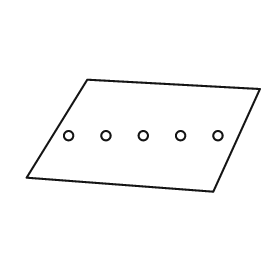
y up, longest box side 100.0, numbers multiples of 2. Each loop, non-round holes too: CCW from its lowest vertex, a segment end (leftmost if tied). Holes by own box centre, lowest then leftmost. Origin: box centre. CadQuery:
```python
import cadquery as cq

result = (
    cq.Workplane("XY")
    .moveTo(30.0, -24.0)
    .lineTo(50.0, 20.0)
    .lineTo(-24.0, 24.0)
    .lineTo(-50.0, -18.0)
    .close()
    .moveTo(-32.0, 0.0)
    .circle(2.0)
    .moveTo(-16.0, 0.0)
    .circle(2.0)
    .moveTo(0.0, 0.0)
    .circle(2.0)
    .moveTo(16.0, 0.0)
    .circle(2.0)
    .moveTo(32.0, 0.0)
    .circle(2.0)
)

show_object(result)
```